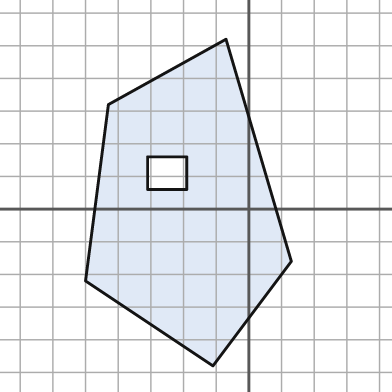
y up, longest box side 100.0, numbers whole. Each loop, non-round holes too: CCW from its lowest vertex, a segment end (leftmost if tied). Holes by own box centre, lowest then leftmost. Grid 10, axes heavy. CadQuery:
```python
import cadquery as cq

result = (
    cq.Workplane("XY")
    .moveTo(-11.0, -48.0)
    .lineTo(13.0, -16.0)
    .lineTo(-7.0, 52.0)
    .lineTo(-43.0, 32.0)
    .lineTo(-50.0, -22.0)
    .close()
    .moveTo(-31.0, 6.0)
    .lineTo(-19.0, 6.0)
    .lineTo(-19.0, 16.0)
    .lineTo(-31.0, 16.0)
    .close()
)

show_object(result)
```